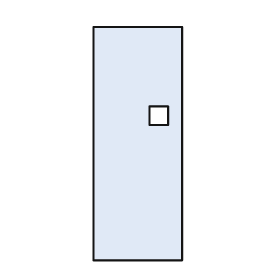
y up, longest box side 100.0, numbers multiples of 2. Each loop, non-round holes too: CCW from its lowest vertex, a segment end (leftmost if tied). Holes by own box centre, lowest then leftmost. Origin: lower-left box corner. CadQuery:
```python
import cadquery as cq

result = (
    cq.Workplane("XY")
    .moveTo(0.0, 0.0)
    .lineTo(38.0, 0.0)
    .lineTo(38.0, 100.0)
    .lineTo(0.0, 100.0)
    .close()
    .moveTo(24.0, 58.0)
    .lineTo(32.0, 58.0)
    .lineTo(32.0, 66.0)
    .lineTo(24.0, 66.0)
    .close()
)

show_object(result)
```